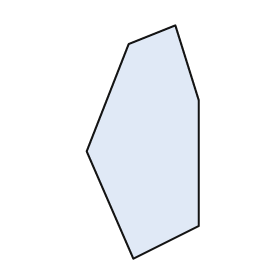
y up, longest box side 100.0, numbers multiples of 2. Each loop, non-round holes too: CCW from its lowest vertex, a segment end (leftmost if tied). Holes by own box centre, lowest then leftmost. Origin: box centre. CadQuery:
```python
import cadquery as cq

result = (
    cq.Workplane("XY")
    .moveTo(-4.0, -50.0)
    .lineTo(24.0, -36.0)
    .lineTo(24.0, 18.0)
    .lineTo(14.0, 50.0)
    .lineTo(-6.0, 42.0)
    .lineTo(-24.0, -4.0)
    .close()
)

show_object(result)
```